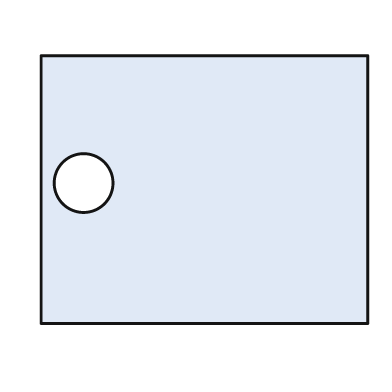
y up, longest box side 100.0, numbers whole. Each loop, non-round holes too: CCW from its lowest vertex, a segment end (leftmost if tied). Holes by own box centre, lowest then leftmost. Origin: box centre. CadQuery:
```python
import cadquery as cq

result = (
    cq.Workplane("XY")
    .moveTo(-50.0, -41.0)
    .lineTo(50.0, -41.0)
    .lineTo(50.0, 41.0)
    .lineTo(-50.0, 41.0)
    .close()
    .moveTo(-37.0, 2.0)
    .circle(9.0)
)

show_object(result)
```